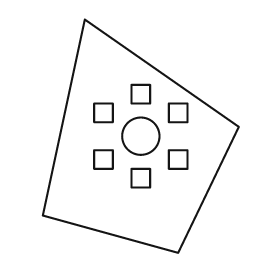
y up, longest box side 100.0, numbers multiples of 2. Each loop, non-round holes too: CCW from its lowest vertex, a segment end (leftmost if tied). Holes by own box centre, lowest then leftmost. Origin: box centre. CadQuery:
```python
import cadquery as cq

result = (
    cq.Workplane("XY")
    .moveTo(16.0, -50.0)
    .lineTo(42.0, 4.0)
    .lineTo(-24.0, 50.0)
    .lineTo(-42.0, -34.0)
    .close()
    .moveTo(-4.0, -22.0)
    .lineTo(4.0, -22.0)
    .lineTo(4.0, -14.0)
    .lineTo(-4.0, -14.0)
    .close()
    .moveTo(-20.0, -14.0)
    .lineTo(-12.0, -14.0)
    .lineTo(-12.0, -6.0)
    .lineTo(-20.0, -6.0)
    .close()
    .moveTo(12.0, -14.0)
    .lineTo(20.0, -14.0)
    .lineTo(20.0, -6.0)
    .lineTo(12.0, -6.0)
    .close()
    .moveTo(0.0, 0.0)
    .circle(8.0)
    .moveTo(-20.0, 6.0)
    .lineTo(-12.0, 6.0)
    .lineTo(-12.0, 14.0)
    .lineTo(-20.0, 14.0)
    .close()
    .moveTo(12.0, 6.0)
    .lineTo(20.0, 6.0)
    .lineTo(20.0, 14.0)
    .lineTo(12.0, 14.0)
    .close()
    .moveTo(-4.0, 14.0)
    .lineTo(4.0, 14.0)
    .lineTo(4.0, 22.0)
    .lineTo(-4.0, 22.0)
    .close()
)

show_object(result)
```